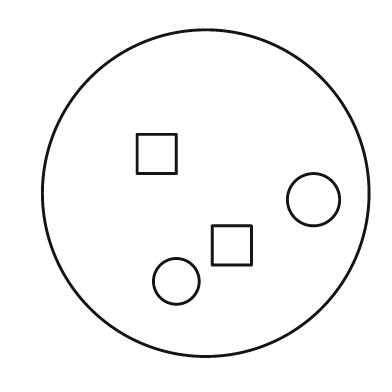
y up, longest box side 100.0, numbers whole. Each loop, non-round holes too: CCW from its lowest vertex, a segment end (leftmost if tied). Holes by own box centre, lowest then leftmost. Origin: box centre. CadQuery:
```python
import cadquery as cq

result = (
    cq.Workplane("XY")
    .moveTo(0.0, 0.0)
    .circle(50.0)
    .moveTo(-9.0, -27.0)
    .circle(7.0)
    .moveTo(2.0, -22.0)
    .lineTo(14.0, -22.0)
    .lineTo(14.0, -10.0)
    .lineTo(2.0, -10.0)
    .close()
    .moveTo(33.0, -2.0)
    .circle(8.0)
    .moveTo(-21.0, 6.0)
    .lineTo(-9.0, 6.0)
    .lineTo(-9.0, 18.0)
    .lineTo(-21.0, 18.0)
    .close()
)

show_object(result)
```